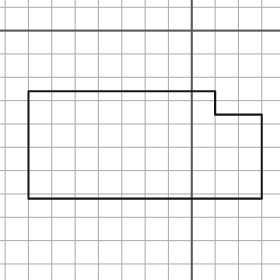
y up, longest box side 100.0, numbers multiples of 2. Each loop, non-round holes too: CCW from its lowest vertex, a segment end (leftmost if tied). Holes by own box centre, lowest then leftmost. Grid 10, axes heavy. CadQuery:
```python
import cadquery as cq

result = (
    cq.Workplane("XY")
    .moveTo(-70.0, -72.0)
    .lineTo(30.0, -72.0)
    .lineTo(30.0, -36.0)
    .lineTo(10.0, -36.0)
    .lineTo(10.0, -26.0)
    .lineTo(-70.0, -26.0)
    .close()
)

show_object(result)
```